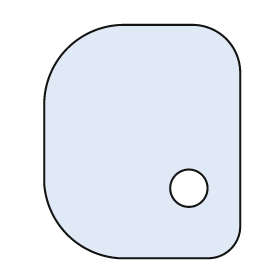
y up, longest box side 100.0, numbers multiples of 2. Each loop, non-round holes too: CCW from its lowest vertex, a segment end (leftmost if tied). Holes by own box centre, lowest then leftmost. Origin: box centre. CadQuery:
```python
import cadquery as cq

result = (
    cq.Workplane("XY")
    .moveTo(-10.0, -50.0)
    .lineTo(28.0, -50.0)
    .threePointArc((38.0, -46.0), (42.0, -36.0))
    .lineTo(42.0, 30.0)
    .threePointArc((36.0, 44.0), (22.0, 50.0))
    .lineTo(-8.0, 50.0)
    .threePointArc((-32.0, 40.0), (-42.0, 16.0))
    .lineTo(-42.0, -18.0)
    .threePointArc((-32.0, -40.0), (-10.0, -50.0))
    .close()
    .moveTo(20.0, -20.0)
    .circle(8.0)
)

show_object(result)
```